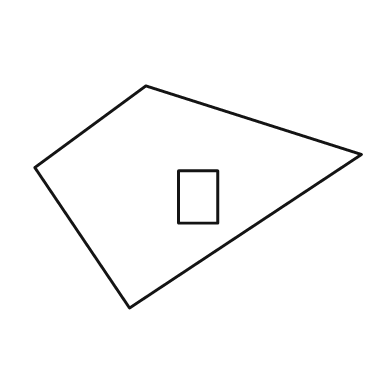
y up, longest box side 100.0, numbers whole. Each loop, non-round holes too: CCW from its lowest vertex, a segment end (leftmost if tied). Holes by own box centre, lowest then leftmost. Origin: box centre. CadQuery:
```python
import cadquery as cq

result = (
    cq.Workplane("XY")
    .moveTo(-21.0, -34.0)
    .lineTo(50.0, 13.0)
    .lineTo(-16.0, 34.0)
    .lineTo(-50.0, 9.0)
    .close()
    .moveTo(-6.0, -8.0)
    .lineTo(6.0, -8.0)
    .lineTo(6.0, 8.0)
    .lineTo(-6.0, 8.0)
    .close()
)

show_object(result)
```